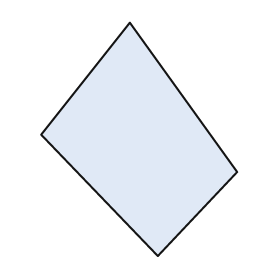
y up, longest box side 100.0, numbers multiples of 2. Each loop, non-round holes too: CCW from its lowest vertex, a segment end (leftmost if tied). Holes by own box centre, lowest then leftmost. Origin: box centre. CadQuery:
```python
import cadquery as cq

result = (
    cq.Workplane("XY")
    .moveTo(8.0, -50.0)
    .lineTo(42.0, -14.0)
    .lineTo(-4.0, 50.0)
    .lineTo(-42.0, 2.0)
    .close()
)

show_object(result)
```